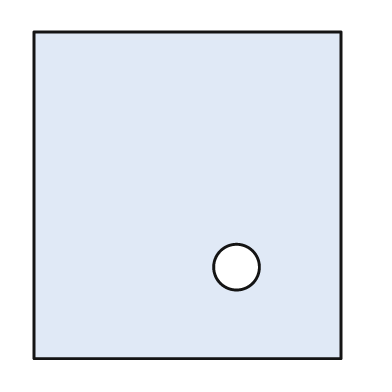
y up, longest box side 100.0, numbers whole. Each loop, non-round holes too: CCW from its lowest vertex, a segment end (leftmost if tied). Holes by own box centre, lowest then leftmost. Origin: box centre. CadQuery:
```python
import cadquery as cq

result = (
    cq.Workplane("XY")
    .moveTo(-47.0, -50.0)
    .lineTo(47.0, -50.0)
    .lineTo(47.0, 50.0)
    .lineTo(-47.0, 50.0)
    .close()
    .moveTo(15.0, -22.0)
    .circle(7.0)
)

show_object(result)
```